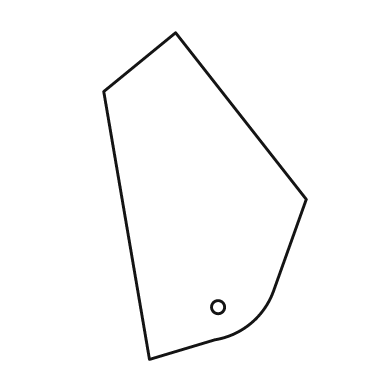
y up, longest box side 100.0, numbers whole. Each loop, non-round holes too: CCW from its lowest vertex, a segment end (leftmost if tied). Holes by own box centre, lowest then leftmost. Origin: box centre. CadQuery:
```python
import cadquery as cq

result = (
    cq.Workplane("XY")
    .moveTo(-17.0, -50.0)
    .lineTo(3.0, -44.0)
    .threePointArc((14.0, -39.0), (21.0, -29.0))
    .lineTo(31.0, -1.0)
    .lineTo(-9.0, 50.0)
    .lineTo(-31.0, 32.0)
    .close()
    .moveTo(4.0, -34.0)
    .circle(2.0)
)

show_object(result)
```